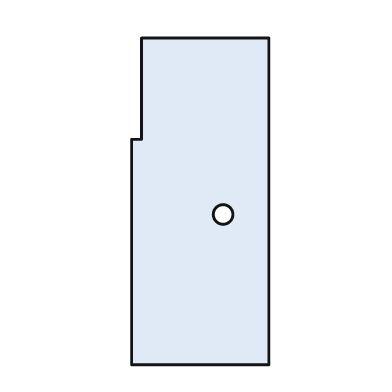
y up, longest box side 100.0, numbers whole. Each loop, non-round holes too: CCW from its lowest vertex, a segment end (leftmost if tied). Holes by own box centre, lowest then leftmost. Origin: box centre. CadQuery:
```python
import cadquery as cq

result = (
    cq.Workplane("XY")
    .moveTo(-21.0, -50.0)
    .lineTo(21.0, -50.0)
    .lineTo(21.0, 50.0)
    .lineTo(-18.0, 50.0)
    .lineTo(-18.0, 19.0)
    .lineTo(-21.0, 19.0)
    .close()
    .moveTo(7.0, -4.0)
    .circle(3.0)
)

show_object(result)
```